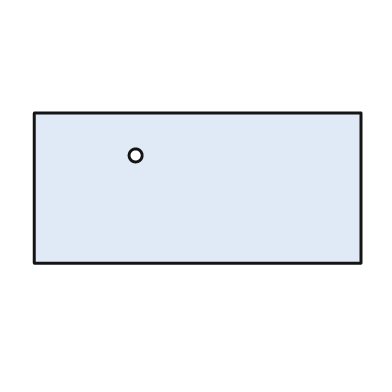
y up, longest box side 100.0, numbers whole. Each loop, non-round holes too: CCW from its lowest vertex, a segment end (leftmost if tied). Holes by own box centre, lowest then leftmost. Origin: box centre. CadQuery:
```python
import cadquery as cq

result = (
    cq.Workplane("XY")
    .moveTo(-50.0, -23.0)
    .lineTo(50.0, -23.0)
    .lineTo(50.0, 23.0)
    .lineTo(-50.0, 23.0)
    .close()
    .moveTo(-19.0, 10.0)
    .circle(2.0)
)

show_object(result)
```